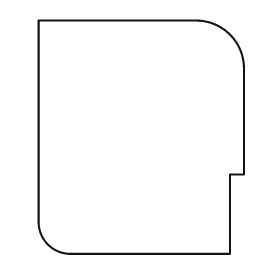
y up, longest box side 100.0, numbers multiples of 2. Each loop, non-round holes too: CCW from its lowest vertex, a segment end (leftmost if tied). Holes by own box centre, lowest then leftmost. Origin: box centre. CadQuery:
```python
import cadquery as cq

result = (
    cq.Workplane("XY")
    .moveTo(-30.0, -50.0)
    .lineTo(38.0, -50.0)
    .lineTo(38.0, -16.0)
    .lineTo(44.0, -16.0)
    .lineTo(44.0, 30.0)
    .threePointArc((38.0, 44.0), (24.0, 50.0))
    .lineTo(-44.0, 50.0)
    .lineTo(-44.0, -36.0)
    .threePointArc((-40.0, -46.0), (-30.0, -50.0))
    .close()
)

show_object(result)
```